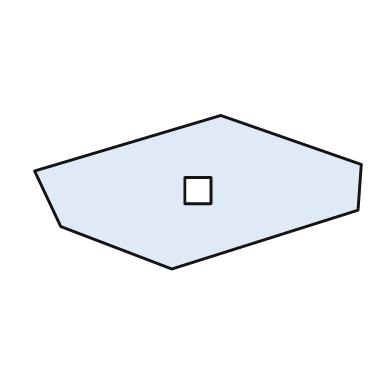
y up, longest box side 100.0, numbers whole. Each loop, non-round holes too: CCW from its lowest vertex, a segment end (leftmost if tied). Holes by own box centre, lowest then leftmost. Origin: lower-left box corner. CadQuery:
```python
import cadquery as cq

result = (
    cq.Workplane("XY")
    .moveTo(42.0, 0.0)
    .lineTo(99.0, 18.0)
    .lineTo(100.0, 32.0)
    .lineTo(57.0, 47.0)
    .lineTo(0.0, 30.0)
    .lineTo(8.0, 13.0)
    .close()
    .moveTo(46.0, 20.0)
    .lineTo(54.0, 20.0)
    .lineTo(54.0, 28.0)
    .lineTo(46.0, 28.0)
    .close()
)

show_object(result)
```